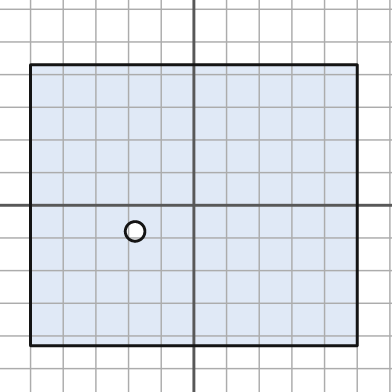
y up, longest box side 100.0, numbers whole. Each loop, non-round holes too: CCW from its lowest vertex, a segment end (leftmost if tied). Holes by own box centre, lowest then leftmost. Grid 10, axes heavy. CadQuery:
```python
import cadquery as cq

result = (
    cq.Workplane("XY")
    .moveTo(-50.0, -43.0)
    .lineTo(50.0, -43.0)
    .lineTo(50.0, 43.0)
    .lineTo(-50.0, 43.0)
    .close()
    .moveTo(-18.0, -8.0)
    .circle(3.0)
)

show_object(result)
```